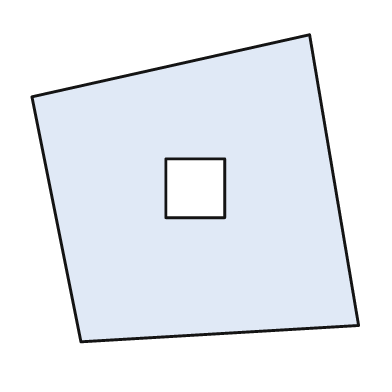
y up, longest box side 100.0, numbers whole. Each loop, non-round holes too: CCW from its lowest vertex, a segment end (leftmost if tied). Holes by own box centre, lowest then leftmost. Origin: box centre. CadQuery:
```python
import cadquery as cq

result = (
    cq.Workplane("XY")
    .moveTo(-35.0, -47.0)
    .lineTo(50.0, -42.0)
    .lineTo(35.0, 47.0)
    .lineTo(-50.0, 28.0)
    .close()
    .moveTo(-9.0, -9.0)
    .lineTo(9.0, -9.0)
    .lineTo(9.0, 9.0)
    .lineTo(-9.0, 9.0)
    .close()
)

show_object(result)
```